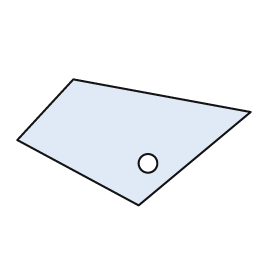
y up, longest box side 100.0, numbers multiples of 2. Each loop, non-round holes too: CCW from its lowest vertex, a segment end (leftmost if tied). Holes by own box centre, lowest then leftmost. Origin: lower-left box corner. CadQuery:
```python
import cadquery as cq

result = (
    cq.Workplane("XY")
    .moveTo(52.0, 0.0)
    .lineTo(100.0, 40.0)
    .lineTo(24.0, 54.0)
    .lineTo(0.0, 28.0)
    .close()
    .moveTo(56.0, 18.0)
    .circle(4.0)
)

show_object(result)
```